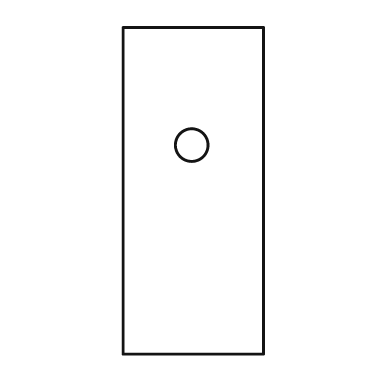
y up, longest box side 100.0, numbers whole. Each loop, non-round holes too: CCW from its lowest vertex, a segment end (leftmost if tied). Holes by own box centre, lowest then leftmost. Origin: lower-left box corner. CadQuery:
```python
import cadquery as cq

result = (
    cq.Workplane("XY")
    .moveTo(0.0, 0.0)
    .lineTo(43.0, 0.0)
    .lineTo(43.0, 100.0)
    .lineTo(0.0, 100.0)
    .close()
    .moveTo(21.0, 64.0)
    .circle(5.0)
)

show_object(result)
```